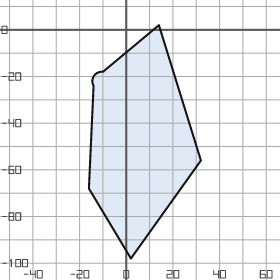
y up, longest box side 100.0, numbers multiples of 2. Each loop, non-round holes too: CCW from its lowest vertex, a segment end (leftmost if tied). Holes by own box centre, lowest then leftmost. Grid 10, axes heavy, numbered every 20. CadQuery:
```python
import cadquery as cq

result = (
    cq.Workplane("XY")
    .moveTo(2.0, -98.0)
    .lineTo(32.0, -56.0)
    .lineTo(14.0, 2.0)
    .lineTo(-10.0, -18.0)
    .threePointArc((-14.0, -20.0), (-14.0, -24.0))
    .lineTo(-16.0, -68.0)
    .close()
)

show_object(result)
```